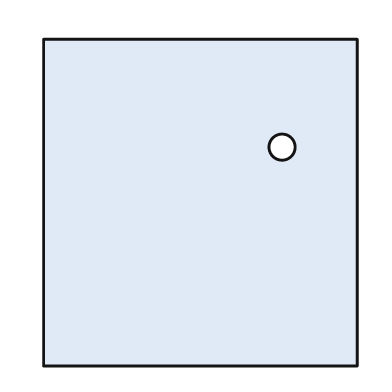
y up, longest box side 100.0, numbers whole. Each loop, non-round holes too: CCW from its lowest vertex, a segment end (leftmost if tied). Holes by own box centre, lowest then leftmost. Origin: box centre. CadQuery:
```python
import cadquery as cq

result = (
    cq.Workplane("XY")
    .moveTo(-48.0, -50.0)
    .lineTo(48.0, -50.0)
    .lineTo(48.0, 50.0)
    .lineTo(-48.0, 50.0)
    .close()
    .moveTo(25.0, 17.0)
    .circle(4.0)
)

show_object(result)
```